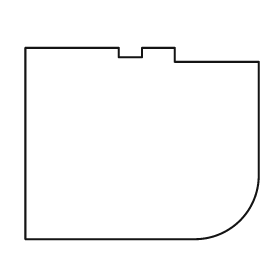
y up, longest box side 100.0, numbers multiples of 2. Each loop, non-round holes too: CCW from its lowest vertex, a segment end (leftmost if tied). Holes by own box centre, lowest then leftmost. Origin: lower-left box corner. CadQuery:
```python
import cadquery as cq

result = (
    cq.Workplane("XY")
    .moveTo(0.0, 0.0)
    .lineTo(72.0, 0.0)
    .threePointArc((92.0, 8.0), (100.0, 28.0))
    .lineTo(100.0, 76.0)
    .lineTo(64.0, 76.0)
    .lineTo(64.0, 82.0)
    .lineTo(50.0, 82.0)
    .lineTo(50.0, 78.0)
    .lineTo(40.0, 78.0)
    .lineTo(40.0, 82.0)
    .lineTo(0.0, 82.0)
    .close()
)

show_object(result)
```